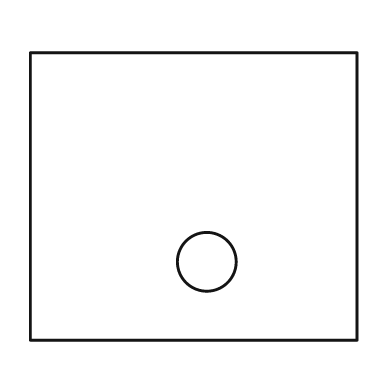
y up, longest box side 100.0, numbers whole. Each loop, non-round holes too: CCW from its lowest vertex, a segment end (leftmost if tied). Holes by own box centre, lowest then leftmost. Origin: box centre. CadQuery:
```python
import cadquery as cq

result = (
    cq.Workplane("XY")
    .moveTo(-50.0, -44.0)
    .lineTo(50.0, -44.0)
    .lineTo(50.0, 44.0)
    .lineTo(-50.0, 44.0)
    .close()
    .moveTo(4.0, -20.0)
    .circle(9.0)
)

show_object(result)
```